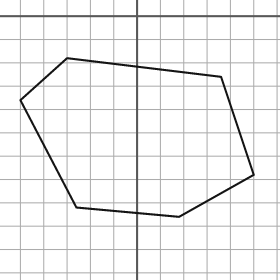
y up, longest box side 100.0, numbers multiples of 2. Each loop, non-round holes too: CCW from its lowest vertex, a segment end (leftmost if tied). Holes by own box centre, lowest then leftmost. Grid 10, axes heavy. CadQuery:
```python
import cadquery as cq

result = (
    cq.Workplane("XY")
    .moveTo(18.0, -86.0)
    .lineTo(50.0, -68.0)
    .lineTo(36.0, -26.0)
    .lineTo(-30.0, -18.0)
    .lineTo(-50.0, -36.0)
    .lineTo(-26.0, -82.0)
    .close()
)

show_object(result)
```